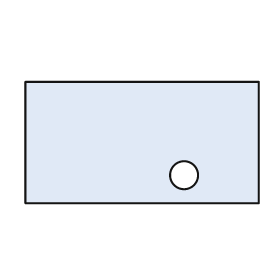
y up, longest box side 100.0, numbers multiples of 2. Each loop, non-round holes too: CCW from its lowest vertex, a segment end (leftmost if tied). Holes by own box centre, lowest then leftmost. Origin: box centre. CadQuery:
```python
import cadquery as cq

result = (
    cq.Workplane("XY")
    .moveTo(-50.0, -26.0)
    .lineTo(50.0, -26.0)
    .lineTo(50.0, 26.0)
    .lineTo(-50.0, 26.0)
    .close()
    .moveTo(18.0, -14.0)
    .circle(6.0)
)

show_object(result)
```